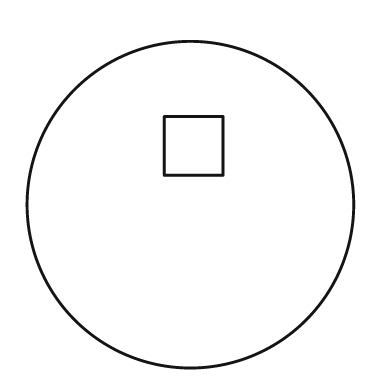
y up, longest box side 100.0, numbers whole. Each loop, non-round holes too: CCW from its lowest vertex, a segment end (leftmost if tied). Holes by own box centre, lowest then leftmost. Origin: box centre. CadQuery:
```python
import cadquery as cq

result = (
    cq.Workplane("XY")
    .moveTo(0.0, 0.0)
    .circle(50.0)
    .moveTo(-8.0, 9.0)
    .lineTo(10.0, 9.0)
    .lineTo(10.0, 27.0)
    .lineTo(-8.0, 27.0)
    .close()
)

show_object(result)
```